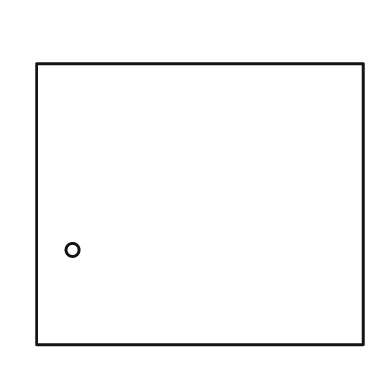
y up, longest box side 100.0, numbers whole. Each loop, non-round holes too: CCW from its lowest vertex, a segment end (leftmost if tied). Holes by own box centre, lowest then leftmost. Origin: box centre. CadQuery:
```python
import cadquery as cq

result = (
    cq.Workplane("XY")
    .moveTo(-50.0, -43.0)
    .lineTo(50.0, -43.0)
    .lineTo(50.0, 43.0)
    .lineTo(-50.0, 43.0)
    .close()
    .moveTo(-39.0, -14.0)
    .circle(2.0)
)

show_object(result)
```